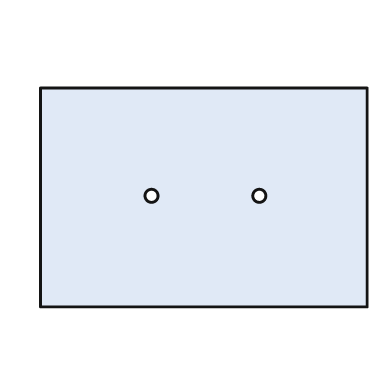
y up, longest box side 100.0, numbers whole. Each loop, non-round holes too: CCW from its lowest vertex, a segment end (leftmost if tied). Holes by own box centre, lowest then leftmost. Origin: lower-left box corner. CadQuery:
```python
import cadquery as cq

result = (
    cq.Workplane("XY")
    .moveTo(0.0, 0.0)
    .lineTo(100.0, 0.0)
    .lineTo(100.0, 67.0)
    .lineTo(0.0, 67.0)
    .close()
    .moveTo(34.0, 34.0)
    .circle(2.0)
    .moveTo(67.0, 34.0)
    .circle(2.0)
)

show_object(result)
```